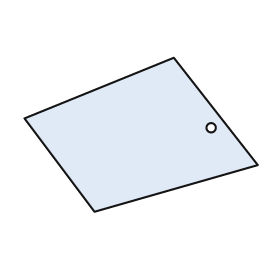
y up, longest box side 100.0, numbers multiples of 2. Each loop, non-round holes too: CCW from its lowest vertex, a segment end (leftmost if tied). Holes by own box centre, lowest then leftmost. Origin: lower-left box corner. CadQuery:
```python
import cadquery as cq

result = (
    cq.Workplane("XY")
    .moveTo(30.0, 0.0)
    .lineTo(100.0, 20.0)
    .lineTo(64.0, 66.0)
    .lineTo(0.0, 40.0)
    .close()
    .moveTo(80.0, 36.0)
    .circle(2.0)
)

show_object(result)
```